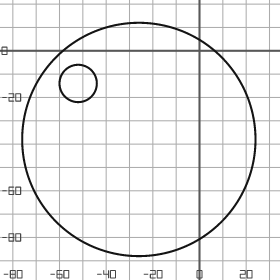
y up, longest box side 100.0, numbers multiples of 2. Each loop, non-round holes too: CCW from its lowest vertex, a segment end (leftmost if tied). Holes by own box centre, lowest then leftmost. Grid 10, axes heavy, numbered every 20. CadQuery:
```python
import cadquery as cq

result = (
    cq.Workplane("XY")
    .moveTo(-26.0, -38.0)
    .circle(50.0)
    .moveTo(-52.0, -14.0)
    .circle(8.0)
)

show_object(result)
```